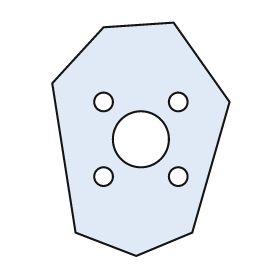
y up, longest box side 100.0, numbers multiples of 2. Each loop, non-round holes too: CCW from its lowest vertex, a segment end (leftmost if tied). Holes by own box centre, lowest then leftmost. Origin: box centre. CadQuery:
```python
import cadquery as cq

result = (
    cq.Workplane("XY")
    .moveTo(-2.0, -50.0)
    .lineTo(22.0, -40.0)
    .lineTo(38.0, 16.0)
    .lineTo(14.0, 50.0)
    .lineTo(-16.0, 48.0)
    .lineTo(-38.0, 24.0)
    .lineTo(-28.0, -40.0)
    .close()
    .moveTo(-16.0, -16.0)
    .circle(4.0)
    .moveTo(16.0, -16.0)
    .circle(4.0)
    .moveTo(0.0, 0.0)
    .circle(12.0)
    .moveTo(-16.0, 16.0)
    .circle(4.0)
    .moveTo(16.0, 16.0)
    .circle(4.0)
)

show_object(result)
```